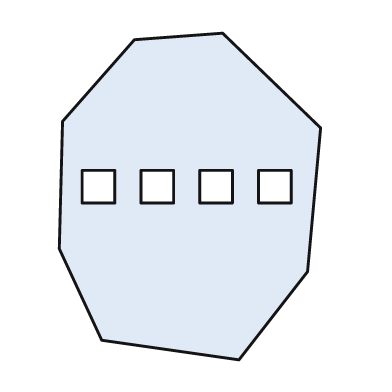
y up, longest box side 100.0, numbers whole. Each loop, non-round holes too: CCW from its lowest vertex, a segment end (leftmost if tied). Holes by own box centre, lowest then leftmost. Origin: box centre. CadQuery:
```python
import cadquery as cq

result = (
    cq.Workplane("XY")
    .moveTo(15.0, -50.0)
    .lineTo(36.0, -23.0)
    .lineTo(40.0, 21.0)
    .lineTo(10.0, 50.0)
    .lineTo(-17.0, 48.0)
    .lineTo(-39.0, 23.0)
    .lineTo(-40.0, -16.0)
    .lineTo(-27.0, -44.0)
    .close()
    .moveTo(-33.0, -2.0)
    .lineTo(-23.0, -2.0)
    .lineTo(-23.0, 8.0)
    .lineTo(-33.0, 8.0)
    .close()
    .moveTo(-15.0, -2.0)
    .lineTo(-5.0, -2.0)
    .lineTo(-5.0, 8.0)
    .lineTo(-15.0, 8.0)
    .close()
    .moveTo(3.0, -2.0)
    .lineTo(13.0, -2.0)
    .lineTo(13.0, 8.0)
    .lineTo(3.0, 8.0)
    .close()
    .moveTo(21.0, -2.0)
    .lineTo(31.0, -2.0)
    .lineTo(31.0, 8.0)
    .lineTo(21.0, 8.0)
    .close()
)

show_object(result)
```